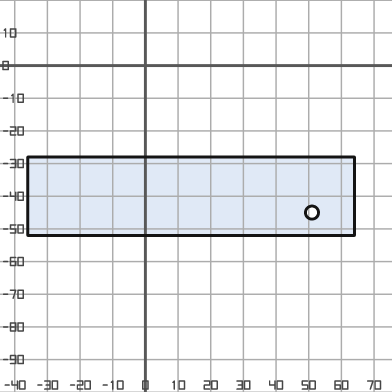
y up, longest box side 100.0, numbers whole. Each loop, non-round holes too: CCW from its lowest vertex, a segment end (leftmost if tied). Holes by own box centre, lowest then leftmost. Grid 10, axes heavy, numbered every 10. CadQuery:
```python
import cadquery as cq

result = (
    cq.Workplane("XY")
    .moveTo(-36.0, -52.0)
    .lineTo(64.0, -52.0)
    .lineTo(64.0, -28.0)
    .lineTo(-36.0, -28.0)
    .close()
    .moveTo(51.0, -45.0)
    .circle(2.0)
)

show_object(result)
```